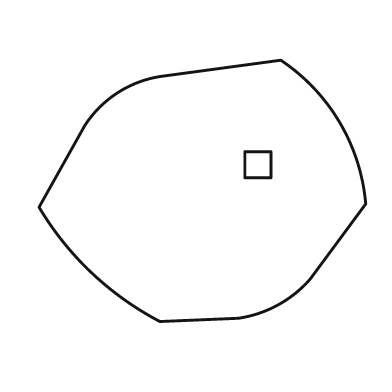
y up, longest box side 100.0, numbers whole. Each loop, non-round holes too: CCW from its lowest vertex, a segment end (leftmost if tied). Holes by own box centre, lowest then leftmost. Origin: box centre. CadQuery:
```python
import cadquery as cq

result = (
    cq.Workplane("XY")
    .moveTo(-13.0, -40.0)
    .lineTo(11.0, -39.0)
    .threePointArc((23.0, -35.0), (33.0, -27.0))
    .lineTo(50.0, -4.0)
    .threePointArc((42.0, 21.0), (24.0, 40.0))
    .lineTo(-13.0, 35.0)
    .threePointArc((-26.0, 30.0), (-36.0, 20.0))
    .lineTo(-50.0, -5.0)
    .threePointArc((-34.0, -25.0), (-13.0, -40.0))
    .close()
    .moveTo(13.0, 4.0)
    .lineTo(21.0, 4.0)
    .lineTo(21.0, 12.0)
    .lineTo(13.0, 12.0)
    .close()
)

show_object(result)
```